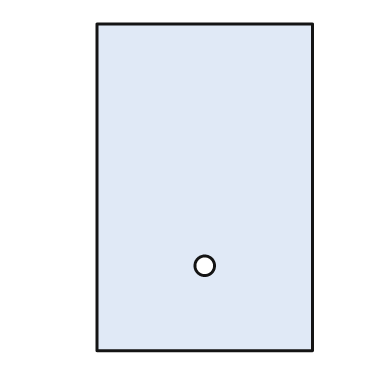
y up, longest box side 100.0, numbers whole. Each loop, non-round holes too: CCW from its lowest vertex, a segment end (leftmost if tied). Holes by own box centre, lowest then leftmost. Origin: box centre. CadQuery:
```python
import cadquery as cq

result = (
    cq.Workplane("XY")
    .moveTo(-33.0, -50.0)
    .lineTo(33.0, -50.0)
    .lineTo(33.0, 50.0)
    .lineTo(-33.0, 50.0)
    .close()
    .moveTo(0.0, -24.0)
    .circle(3.0)
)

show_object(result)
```